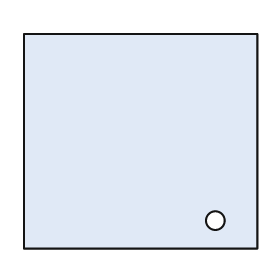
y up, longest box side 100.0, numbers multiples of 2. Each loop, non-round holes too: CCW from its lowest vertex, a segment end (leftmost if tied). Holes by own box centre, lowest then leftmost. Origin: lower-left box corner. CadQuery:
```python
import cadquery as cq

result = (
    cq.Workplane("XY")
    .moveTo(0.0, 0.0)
    .lineTo(100.0, 0.0)
    .lineTo(100.0, 92.0)
    .lineTo(0.0, 92.0)
    .close()
    .moveTo(82.0, 12.0)
    .circle(4.0)
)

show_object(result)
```